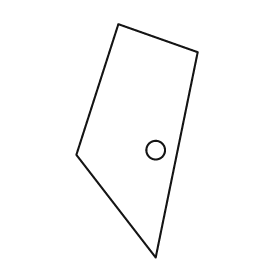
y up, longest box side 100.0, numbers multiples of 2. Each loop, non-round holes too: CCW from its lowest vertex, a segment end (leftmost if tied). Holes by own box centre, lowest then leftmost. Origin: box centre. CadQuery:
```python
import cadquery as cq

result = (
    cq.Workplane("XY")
    .moveTo(8.0, -50.0)
    .lineTo(26.0, 38.0)
    .lineTo(-8.0, 50.0)
    .lineTo(-26.0, -6.0)
    .close()
    .moveTo(8.0, -4.0)
    .circle(4.0)
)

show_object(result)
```